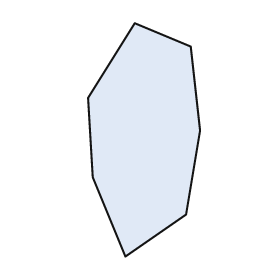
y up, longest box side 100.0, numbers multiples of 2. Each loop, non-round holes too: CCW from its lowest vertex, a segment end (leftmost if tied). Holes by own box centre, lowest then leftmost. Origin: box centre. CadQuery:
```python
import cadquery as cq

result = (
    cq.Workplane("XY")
    .moveTo(-8.0, -50.0)
    .lineTo(18.0, -32.0)
    .lineTo(24.0, 4.0)
    .lineTo(20.0, 40.0)
    .lineTo(-4.0, 50.0)
    .lineTo(-24.0, 18.0)
    .lineTo(-22.0, -16.0)
    .close()
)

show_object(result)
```